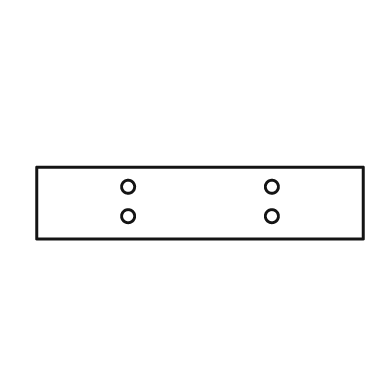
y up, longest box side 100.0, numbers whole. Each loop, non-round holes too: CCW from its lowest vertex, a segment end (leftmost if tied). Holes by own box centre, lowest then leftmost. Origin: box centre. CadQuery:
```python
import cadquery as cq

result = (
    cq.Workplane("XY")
    .moveTo(-50.0, -11.0)
    .lineTo(50.0, -11.0)
    .lineTo(50.0, 11.0)
    .lineTo(-50.0, 11.0)
    .close()
    .moveTo(-22.0, -4.0)
    .circle(2.0)
    .moveTo(22.0, -4.0)
    .circle(2.0)
    .moveTo(-22.0, 5.0)
    .circle(2.0)
    .moveTo(22.0, 5.0)
    .circle(2.0)
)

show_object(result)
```